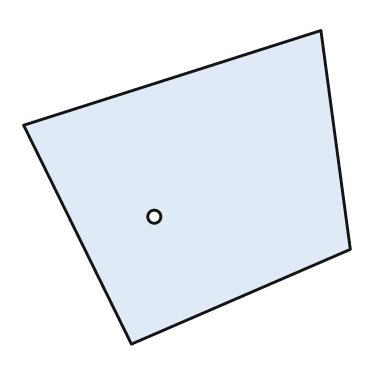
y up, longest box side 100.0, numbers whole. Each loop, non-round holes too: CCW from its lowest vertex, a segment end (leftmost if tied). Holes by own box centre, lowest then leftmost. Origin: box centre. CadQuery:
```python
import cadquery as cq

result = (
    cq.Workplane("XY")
    .moveTo(-17.0, -48.0)
    .lineTo(50.0, -19.0)
    .lineTo(41.0, 48.0)
    .lineTo(-50.0, 19.0)
    .close()
    .moveTo(-10.0, -9.0)
    .circle(2.0)
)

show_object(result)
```